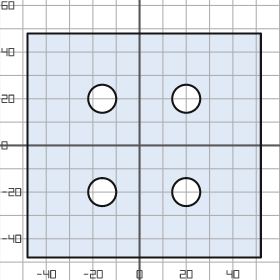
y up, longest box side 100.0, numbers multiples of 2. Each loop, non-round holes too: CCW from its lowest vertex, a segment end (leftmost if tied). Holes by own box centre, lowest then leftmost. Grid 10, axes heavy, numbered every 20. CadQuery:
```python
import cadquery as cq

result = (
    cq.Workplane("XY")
    .moveTo(-48.0, -48.0)
    .lineTo(52.0, -48.0)
    .lineTo(52.0, 48.0)
    .lineTo(-48.0, 48.0)
    .close()
    .moveTo(-16.0, -20.0)
    .circle(6.0)
    .moveTo(20.0, -20.0)
    .circle(6.0)
    .moveTo(-16.0, 20.0)
    .circle(6.0)
    .moveTo(20.0, 20.0)
    .circle(6.0)
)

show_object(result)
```